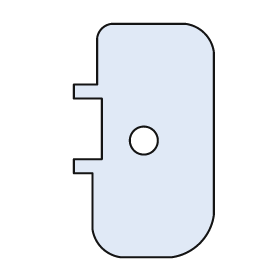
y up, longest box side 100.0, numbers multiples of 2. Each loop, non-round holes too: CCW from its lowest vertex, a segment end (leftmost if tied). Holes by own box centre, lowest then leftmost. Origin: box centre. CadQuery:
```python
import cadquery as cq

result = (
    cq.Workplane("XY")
    .moveTo(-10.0, -50.0)
    .lineTo(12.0, -50.0)
    .threePointArc((24.0, -44.0), (30.0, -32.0))
    .lineTo(30.0, 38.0)
    .threePointArc((26.0, 46.0), (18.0, 50.0))
    .lineTo(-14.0, 50.0)
    .threePointArc((-18.0, 48.0), (-20.0, 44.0))
    .lineTo(-20.0, 24.0)
    .lineTo(-30.0, 24.0)
    .lineTo(-30.0, 18.0)
    .lineTo(-18.0, 18.0)
    .lineTo(-18.0, -8.0)
    .lineTo(-30.0, -8.0)
    .lineTo(-30.0, -14.0)
    .lineTo(-22.0, -14.0)
    .lineTo(-22.0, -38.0)
    .threePointArc((-18.0, -46.0), (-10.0, -50.0))
    .close()
    .moveTo(0.0, 0.0)
    .circle(6.0)
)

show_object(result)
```